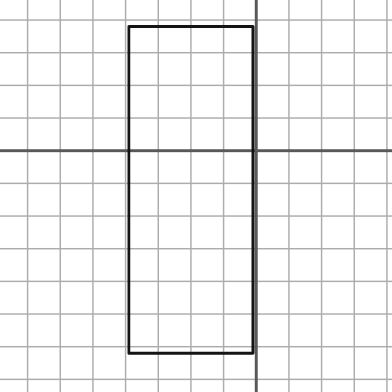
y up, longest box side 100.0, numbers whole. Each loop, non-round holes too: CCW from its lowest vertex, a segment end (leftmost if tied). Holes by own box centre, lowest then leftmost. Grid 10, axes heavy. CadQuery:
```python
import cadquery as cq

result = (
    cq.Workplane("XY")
    .moveTo(-39.0, -62.0)
    .lineTo(-1.0, -62.0)
    .lineTo(-1.0, 38.0)
    .lineTo(-39.0, 38.0)
    .close()
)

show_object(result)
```